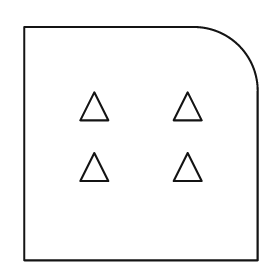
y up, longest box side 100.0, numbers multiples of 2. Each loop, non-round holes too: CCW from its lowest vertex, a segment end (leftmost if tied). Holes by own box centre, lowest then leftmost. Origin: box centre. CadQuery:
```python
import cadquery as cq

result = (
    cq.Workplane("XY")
    .moveTo(-50.0, -50.0)
    .lineTo(50.0, -50.0)
    .lineTo(50.0, 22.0)
    .threePointArc((42.0, 42.0), (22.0, 50.0))
    .lineTo(-50.0, 50.0)
    .close()
    .moveTo(-26.0, -16.0)
    .lineTo(-14.0, -16.0)
    .lineTo(-20.0, -4.0)
    .close()
    .moveTo(14.0, -16.0)
    .lineTo(26.0, -16.0)
    .lineTo(20.0, -4.0)
    .close()
    .moveTo(-26.0, 10.0)
    .lineTo(-14.0, 10.0)
    .lineTo(-20.0, 22.0)
    .close()
    .moveTo(14.0, 10.0)
    .lineTo(26.0, 10.0)
    .lineTo(20.0, 22.0)
    .close()
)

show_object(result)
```